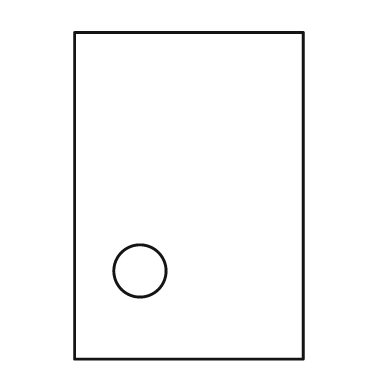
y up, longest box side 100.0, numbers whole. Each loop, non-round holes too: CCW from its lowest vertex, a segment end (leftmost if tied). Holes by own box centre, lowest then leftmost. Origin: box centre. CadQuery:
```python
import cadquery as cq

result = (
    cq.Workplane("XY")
    .moveTo(-35.0, -50.0)
    .lineTo(35.0, -50.0)
    .lineTo(35.0, 50.0)
    .lineTo(-35.0, 50.0)
    .close()
    .moveTo(-15.0, -23.0)
    .circle(8.0)
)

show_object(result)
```